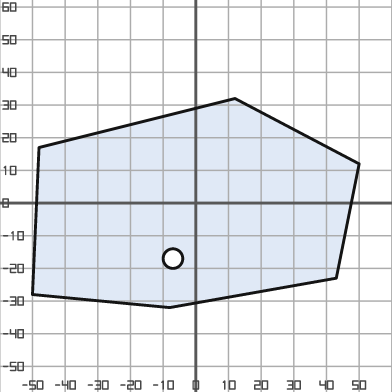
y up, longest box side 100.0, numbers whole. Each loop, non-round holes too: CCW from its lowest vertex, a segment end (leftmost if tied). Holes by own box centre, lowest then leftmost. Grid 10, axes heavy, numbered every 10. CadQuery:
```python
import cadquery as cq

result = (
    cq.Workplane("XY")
    .moveTo(-8.0, -32.0)
    .lineTo(43.0, -23.0)
    .lineTo(50.0, 12.0)
    .lineTo(12.0, 32.0)
    .lineTo(-48.0, 17.0)
    .lineTo(-50.0, -28.0)
    .close()
    .moveTo(-7.0, -17.0)
    .circle(3.0)
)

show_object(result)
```